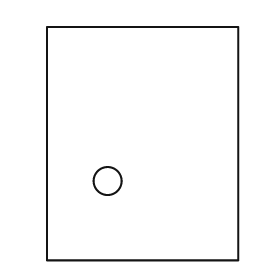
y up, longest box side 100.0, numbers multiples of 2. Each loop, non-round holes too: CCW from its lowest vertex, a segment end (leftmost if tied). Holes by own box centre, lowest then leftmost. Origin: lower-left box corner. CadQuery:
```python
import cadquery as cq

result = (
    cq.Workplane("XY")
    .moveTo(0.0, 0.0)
    .lineTo(82.0, 0.0)
    .lineTo(82.0, 100.0)
    .lineTo(0.0, 100.0)
    .close()
    .moveTo(26.0, 34.0)
    .circle(6.0)
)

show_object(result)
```